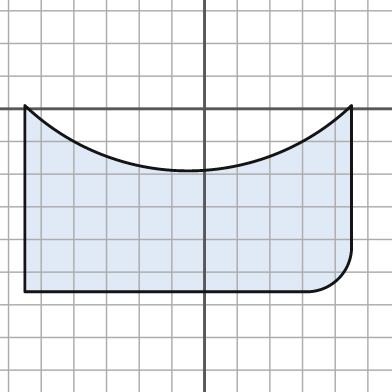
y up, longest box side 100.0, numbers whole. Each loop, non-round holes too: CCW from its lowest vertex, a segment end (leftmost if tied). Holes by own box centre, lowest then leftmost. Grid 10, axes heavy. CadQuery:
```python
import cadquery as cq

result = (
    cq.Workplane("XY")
    .moveTo(-55.0, -56.0)
    .lineTo(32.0, -56.0)
    .threePointArc((41.0, -52.0), (45.0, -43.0))
    .lineTo(45.0, 1.0)
    .threePointArc((-5.0, -19.0), (-55.0, 1.0))
    .close()
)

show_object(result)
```